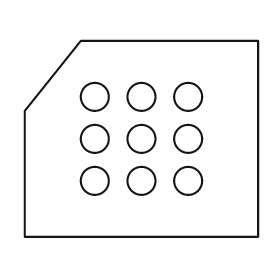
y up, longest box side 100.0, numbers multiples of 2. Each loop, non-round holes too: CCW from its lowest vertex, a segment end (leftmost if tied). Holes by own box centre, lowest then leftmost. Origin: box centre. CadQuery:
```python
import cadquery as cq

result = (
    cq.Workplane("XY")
    .moveTo(-50.0, -42.0)
    .lineTo(50.0, -42.0)
    .lineTo(50.0, 42.0)
    .lineTo(-26.0, 42.0)
    .lineTo(-50.0, 12.0)
    .close()
    .moveTo(-20.0, -18.0)
    .circle(6.0)
    .moveTo(0.0, -18.0)
    .circle(6.0)
    .moveTo(20.0, -18.0)
    .circle(6.0)
    .moveTo(-20.0, 0.0)
    .circle(6.0)
    .moveTo(0.0, 0.0)
    .circle(6.0)
    .moveTo(20.0, 0.0)
    .circle(6.0)
    .moveTo(-20.0, 18.0)
    .circle(6.0)
    .moveTo(0.0, 18.0)
    .circle(6.0)
    .moveTo(20.0, 18.0)
    .circle(6.0)
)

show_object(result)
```